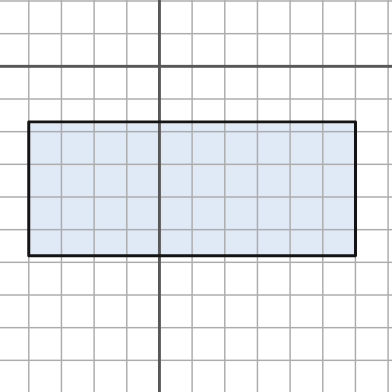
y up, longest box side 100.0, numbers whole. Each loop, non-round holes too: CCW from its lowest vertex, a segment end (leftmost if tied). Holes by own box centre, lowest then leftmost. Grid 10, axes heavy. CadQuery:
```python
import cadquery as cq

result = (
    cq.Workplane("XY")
    .moveTo(-40.0, -58.0)
    .lineTo(60.0, -58.0)
    .lineTo(60.0, -17.0)
    .lineTo(-40.0, -17.0)
    .close()
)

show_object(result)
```